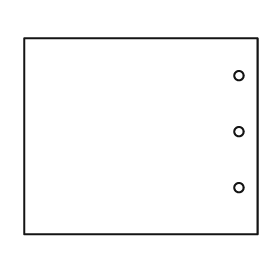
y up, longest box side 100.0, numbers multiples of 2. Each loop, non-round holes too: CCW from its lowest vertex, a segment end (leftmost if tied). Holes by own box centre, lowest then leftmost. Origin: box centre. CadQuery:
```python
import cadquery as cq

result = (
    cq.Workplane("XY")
    .moveTo(-50.0, -42.0)
    .lineTo(50.0, -42.0)
    .lineTo(50.0, 42.0)
    .lineTo(-50.0, 42.0)
    .close()
    .moveTo(42.0, -22.0)
    .circle(2.0)
    .moveTo(42.0, 2.0)
    .circle(2.0)
    .moveTo(42.0, 26.0)
    .circle(2.0)
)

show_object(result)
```